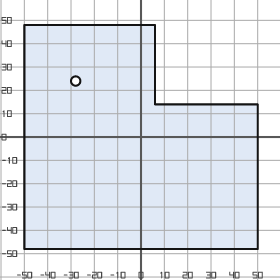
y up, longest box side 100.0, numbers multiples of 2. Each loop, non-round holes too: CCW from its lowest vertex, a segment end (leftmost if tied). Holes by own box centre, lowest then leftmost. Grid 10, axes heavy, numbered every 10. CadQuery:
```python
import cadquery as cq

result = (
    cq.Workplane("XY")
    .moveTo(-50.0, -48.0)
    .lineTo(50.0, -48.0)
    .lineTo(50.0, 14.0)
    .lineTo(6.0, 14.0)
    .lineTo(6.0, 48.0)
    .lineTo(-50.0, 48.0)
    .close()
    .moveTo(-28.0, 24.0)
    .circle(2.0)
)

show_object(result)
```